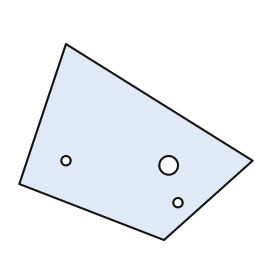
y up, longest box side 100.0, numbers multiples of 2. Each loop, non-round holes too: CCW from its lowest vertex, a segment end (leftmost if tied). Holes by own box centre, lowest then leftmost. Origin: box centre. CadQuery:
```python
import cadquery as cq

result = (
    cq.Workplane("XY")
    .moveTo(12.0, -42.0)
    .lineTo(50.0, -8.0)
    .lineTo(-30.0, 42.0)
    .lineTo(-50.0, -18.0)
    .close()
    .moveTo(18.0, -26.0)
    .circle(2.0)
    .moveTo(14.0, -10.0)
    .circle(4.0)
    .moveTo(-30.0, -8.0)
    .circle(2.0)
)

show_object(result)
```